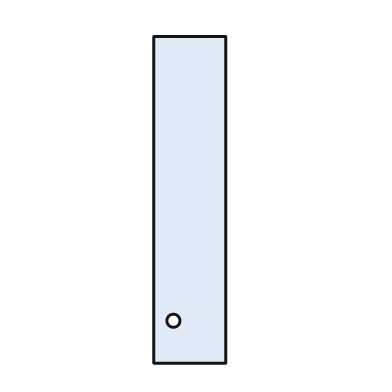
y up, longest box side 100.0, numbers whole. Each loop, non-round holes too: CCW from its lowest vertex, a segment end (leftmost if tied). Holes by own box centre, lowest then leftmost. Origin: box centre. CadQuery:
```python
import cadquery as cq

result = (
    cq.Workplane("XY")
    .moveTo(-11.0, -50.0)
    .lineTo(11.0, -50.0)
    .lineTo(11.0, 50.0)
    .lineTo(-11.0, 50.0)
    .close()
    .moveTo(-5.0, -37.0)
    .circle(2.0)
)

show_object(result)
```